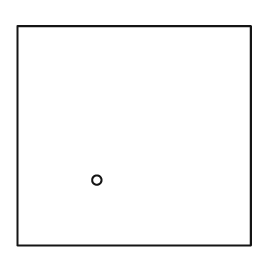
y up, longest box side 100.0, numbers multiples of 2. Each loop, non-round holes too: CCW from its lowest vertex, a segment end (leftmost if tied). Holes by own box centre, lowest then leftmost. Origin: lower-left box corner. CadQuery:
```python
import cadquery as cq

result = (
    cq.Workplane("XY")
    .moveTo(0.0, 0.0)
    .lineTo(100.0, 0.0)
    .lineTo(100.0, 94.0)
    .lineTo(0.0, 94.0)
    .close()
    .moveTo(34.0, 28.0)
    .circle(2.0)
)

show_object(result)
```